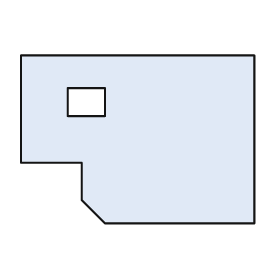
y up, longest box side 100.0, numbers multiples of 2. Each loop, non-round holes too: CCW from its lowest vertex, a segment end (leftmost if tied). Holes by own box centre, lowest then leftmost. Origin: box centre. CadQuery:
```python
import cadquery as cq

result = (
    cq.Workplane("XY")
    .moveTo(-14.0, -36.0)
    .lineTo(50.0, -36.0)
    .lineTo(50.0, 36.0)
    .lineTo(-50.0, 36.0)
    .lineTo(-50.0, -10.0)
    .lineTo(-24.0, -10.0)
    .lineTo(-24.0, -26.0)
    .close()
    .moveTo(-30.0, 10.0)
    .lineTo(-14.0, 10.0)
    .lineTo(-14.0, 22.0)
    .lineTo(-30.0, 22.0)
    .close()
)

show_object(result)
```